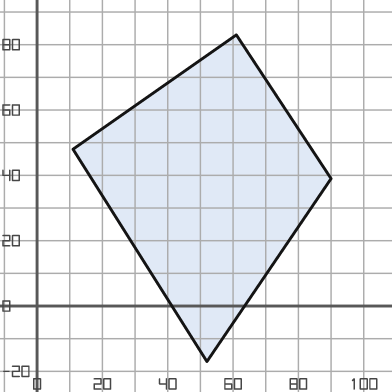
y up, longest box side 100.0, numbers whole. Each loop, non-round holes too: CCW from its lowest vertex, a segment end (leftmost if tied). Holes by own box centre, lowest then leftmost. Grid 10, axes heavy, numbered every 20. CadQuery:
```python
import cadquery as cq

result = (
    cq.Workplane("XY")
    .moveTo(52.0, -17.0)
    .lineTo(90.0, 39.0)
    .lineTo(61.0, 83.0)
    .lineTo(11.0, 48.0)
    .close()
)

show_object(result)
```